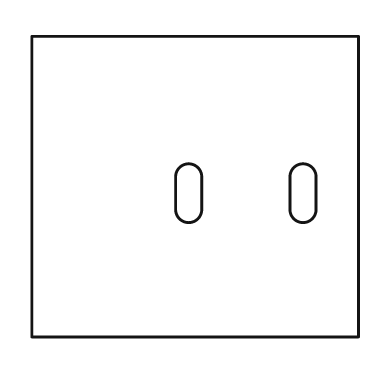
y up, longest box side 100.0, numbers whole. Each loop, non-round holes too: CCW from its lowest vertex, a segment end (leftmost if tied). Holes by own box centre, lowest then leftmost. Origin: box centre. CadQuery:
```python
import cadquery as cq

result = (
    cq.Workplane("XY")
    .moveTo(-50.0, -46.0)
    .lineTo(50.0, -46.0)
    .lineTo(50.0, 46.0)
    .lineTo(-50.0, 46.0)
    .close()
    .moveTo(-6.0, -7.0)
    .threePointArc((-2.0, -11.0), (2.0, -7.0))
    .lineTo(2.0, 3.0)
    .threePointArc((-2.0, 7.0), (-6.0, 3.0))
    .close()
    .moveTo(29.0, -7.0)
    .threePointArc((33.0, -11.0), (37.0, -7.0))
    .lineTo(37.0, 3.0)
    .threePointArc((33.0, 7.0), (29.0, 3.0))
    .close()
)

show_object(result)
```